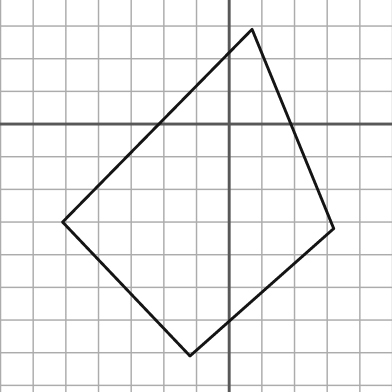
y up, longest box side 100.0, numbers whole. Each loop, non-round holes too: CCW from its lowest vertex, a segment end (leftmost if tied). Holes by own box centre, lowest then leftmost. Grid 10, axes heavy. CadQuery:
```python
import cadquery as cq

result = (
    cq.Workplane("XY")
    .moveTo(-12.0, -71.0)
    .lineTo(32.0, -32.0)
    .lineTo(7.0, 29.0)
    .lineTo(-51.0, -30.0)
    .close()
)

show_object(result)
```